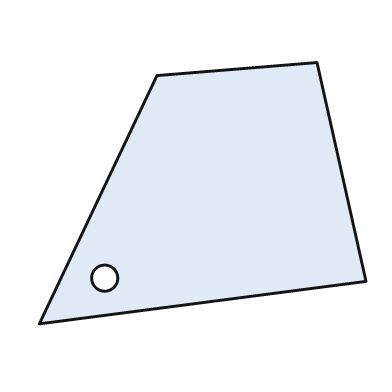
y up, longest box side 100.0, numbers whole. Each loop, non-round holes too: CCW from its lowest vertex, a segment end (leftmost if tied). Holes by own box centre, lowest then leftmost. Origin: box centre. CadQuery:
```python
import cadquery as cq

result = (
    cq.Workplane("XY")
    .moveTo(-50.0, -40.0)
    .lineTo(50.0, -27.0)
    .lineTo(35.0, 40.0)
    .lineTo(-14.0, 36.0)
    .close()
    .moveTo(-30.0, -26.0)
    .circle(4.0)
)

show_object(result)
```